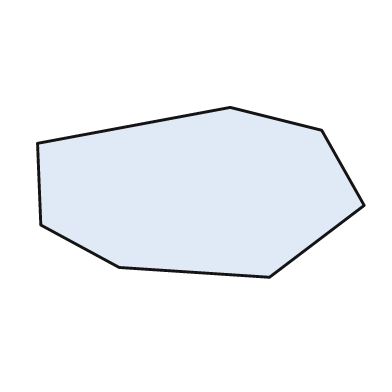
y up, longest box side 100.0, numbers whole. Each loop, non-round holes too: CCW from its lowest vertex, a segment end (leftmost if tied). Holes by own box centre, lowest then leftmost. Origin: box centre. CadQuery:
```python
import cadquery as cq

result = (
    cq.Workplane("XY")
    .moveTo(21.0, -26.0)
    .lineTo(50.0, -4.0)
    .lineTo(37.0, 19.0)
    .lineTo(9.0, 26.0)
    .lineTo(-50.0, 15.0)
    .lineTo(-49.0, -10.0)
    .lineTo(-25.0, -23.0)
    .close()
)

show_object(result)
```